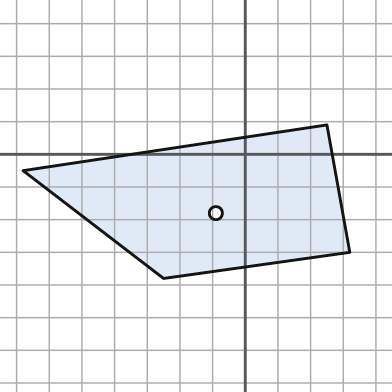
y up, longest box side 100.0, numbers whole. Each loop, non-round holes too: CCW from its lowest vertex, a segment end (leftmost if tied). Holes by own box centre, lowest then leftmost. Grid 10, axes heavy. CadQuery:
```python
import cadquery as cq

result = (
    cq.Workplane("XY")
    .moveTo(-25.0, -38.0)
    .lineTo(32.0, -30.0)
    .lineTo(25.0, 9.0)
    .lineTo(-68.0, -5.0)
    .close()
    .moveTo(-9.0, -18.0)
    .circle(2.0)
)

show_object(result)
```